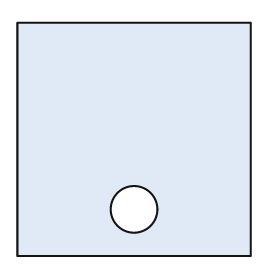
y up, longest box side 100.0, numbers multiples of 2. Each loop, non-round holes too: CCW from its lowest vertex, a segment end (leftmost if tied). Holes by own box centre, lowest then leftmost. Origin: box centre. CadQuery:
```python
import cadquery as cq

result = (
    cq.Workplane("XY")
    .moveTo(-50.0, -50.0)
    .lineTo(50.0, -50.0)
    .lineTo(50.0, 50.0)
    .lineTo(-50.0, 50.0)
    .close()
    .moveTo(0.0, -30.0)
    .circle(10.0)
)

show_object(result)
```